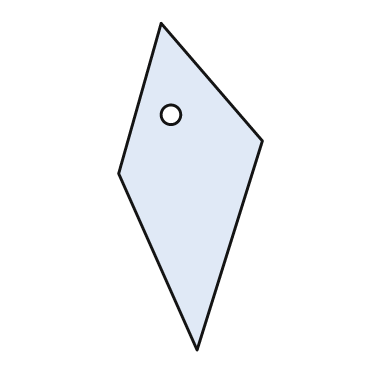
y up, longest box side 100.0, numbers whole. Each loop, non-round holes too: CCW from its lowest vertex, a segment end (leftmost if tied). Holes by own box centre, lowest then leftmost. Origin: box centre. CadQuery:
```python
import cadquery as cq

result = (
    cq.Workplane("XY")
    .moveTo(2.0, -50.0)
    .lineTo(22.0, 14.0)
    .lineTo(-9.0, 50.0)
    .lineTo(-22.0, 4.0)
    .close()
    .moveTo(-6.0, 22.0)
    .circle(3.0)
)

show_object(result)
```